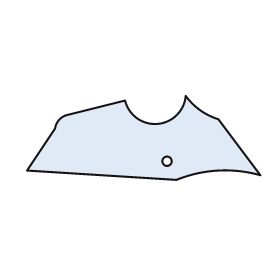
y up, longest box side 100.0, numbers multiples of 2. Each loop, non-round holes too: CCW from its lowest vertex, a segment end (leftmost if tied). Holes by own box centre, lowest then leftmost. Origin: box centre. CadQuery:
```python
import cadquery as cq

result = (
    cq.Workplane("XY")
    .moveTo(14.0, -18.0)
    .threePointArc((32.0, -14.0), (50.0, -16.0))
    .lineTo(32.0, 8.0)
    .threePointArc((24.0, 12.0), (18.0, 18.0))
    .threePointArc((6.0, 6.0), (-8.0, 16.0))
    .lineTo(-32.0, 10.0)
    .threePointArc((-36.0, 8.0), (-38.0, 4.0))
    .lineTo(-50.0, -14.0)
    .close()
    .moveTo(10.0, -10.0)
    .circle(2.0)
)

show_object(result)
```